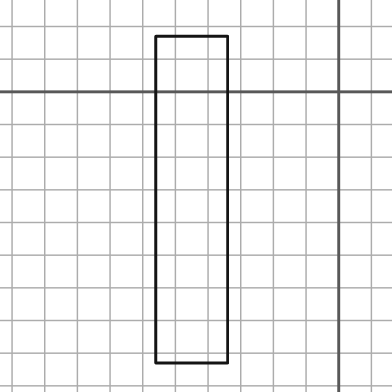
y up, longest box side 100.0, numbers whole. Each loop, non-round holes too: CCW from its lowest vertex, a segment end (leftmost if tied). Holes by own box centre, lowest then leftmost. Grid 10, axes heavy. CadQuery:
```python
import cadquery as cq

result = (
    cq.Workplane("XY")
    .moveTo(-56.0, -83.0)
    .lineTo(-34.0, -83.0)
    .lineTo(-34.0, 17.0)
    .lineTo(-56.0, 17.0)
    .close()
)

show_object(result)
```